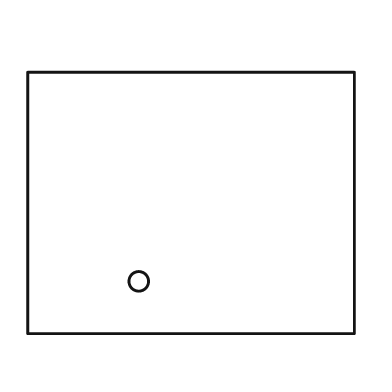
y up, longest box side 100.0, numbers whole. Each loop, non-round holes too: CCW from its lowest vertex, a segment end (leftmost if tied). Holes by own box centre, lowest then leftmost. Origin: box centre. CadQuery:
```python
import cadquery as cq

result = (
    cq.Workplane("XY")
    .moveTo(-50.0, -40.0)
    .lineTo(50.0, -40.0)
    .lineTo(50.0, 40.0)
    .lineTo(-50.0, 40.0)
    .close()
    .moveTo(-16.0, -24.0)
    .circle(3.0)
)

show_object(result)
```